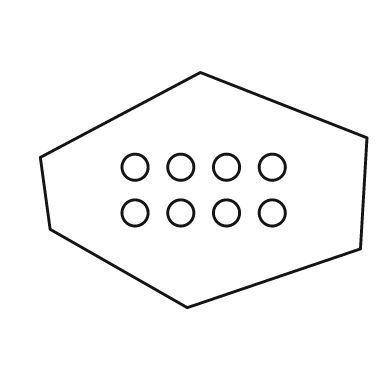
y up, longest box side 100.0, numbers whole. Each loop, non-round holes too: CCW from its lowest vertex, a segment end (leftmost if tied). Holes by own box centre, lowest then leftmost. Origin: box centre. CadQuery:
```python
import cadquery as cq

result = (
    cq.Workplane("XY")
    .moveTo(-5.0, -36.0)
    .lineTo(48.0, -18.0)
    .lineTo(50.0, 16.0)
    .lineTo(-1.0, 36.0)
    .lineTo(-50.0, 10.0)
    .lineTo(-47.0, -12.0)
    .close()
    .moveTo(-21.0, -7.0)
    .circle(4.0)
    .moveTo(-7.0, -7.0)
    .circle(4.0)
    .moveTo(7.0, -7.0)
    .circle(4.0)
    .moveTo(21.0, -7.0)
    .circle(4.0)
    .moveTo(-21.0, 7.0)
    .circle(4.0)
    .moveTo(-7.0, 7.0)
    .circle(4.0)
    .moveTo(7.0, 7.0)
    .circle(4.0)
    .moveTo(21.0, 7.0)
    .circle(4.0)
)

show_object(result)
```